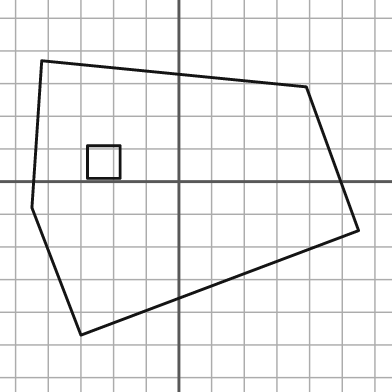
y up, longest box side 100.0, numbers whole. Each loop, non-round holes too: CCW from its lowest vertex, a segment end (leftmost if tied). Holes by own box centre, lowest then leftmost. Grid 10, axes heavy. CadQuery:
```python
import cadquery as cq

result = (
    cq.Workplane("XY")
    .moveTo(-30.0, -47.0)
    .lineTo(55.0, -15.0)
    .lineTo(39.0, 29.0)
    .lineTo(-42.0, 37.0)
    .lineTo(-45.0, -8.0)
    .close()
    .moveTo(-28.0, 1.0)
    .lineTo(-18.0, 1.0)
    .lineTo(-18.0, 11.0)
    .lineTo(-28.0, 11.0)
    .close()
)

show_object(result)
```